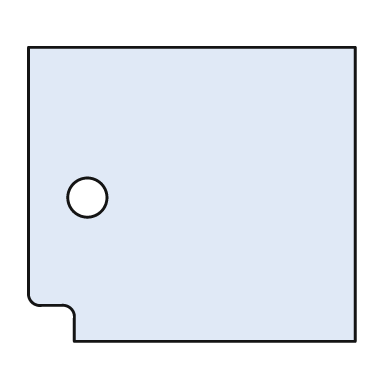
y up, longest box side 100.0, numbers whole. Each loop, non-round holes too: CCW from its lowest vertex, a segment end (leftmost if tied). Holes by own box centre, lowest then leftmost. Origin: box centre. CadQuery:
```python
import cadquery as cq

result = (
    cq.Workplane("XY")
    .moveTo(-36.0, -45.0)
    .lineTo(50.0, -45.0)
    .lineTo(50.0, 45.0)
    .lineTo(-50.0, 45.0)
    .lineTo(-50.0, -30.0)
    .threePointArc((-49.0, -33.0), (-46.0, -34.0))
    .lineTo(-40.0, -34.0)
    .threePointArc((-37.0, -35.0), (-36.0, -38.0))
    .close()
    .moveTo(-32.0, -1.0)
    .circle(6.0)
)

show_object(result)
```